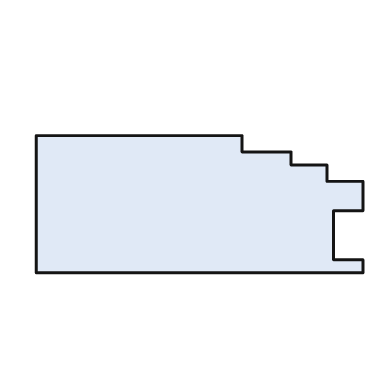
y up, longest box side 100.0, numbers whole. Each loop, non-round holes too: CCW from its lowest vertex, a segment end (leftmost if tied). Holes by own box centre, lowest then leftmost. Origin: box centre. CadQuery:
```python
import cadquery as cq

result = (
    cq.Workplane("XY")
    .moveTo(-50.0, -21.0)
    .lineTo(50.0, -21.0)
    .lineTo(50.0, -17.0)
    .lineTo(41.0, -17.0)
    .lineTo(41.0, -2.0)
    .lineTo(50.0, -2.0)
    .lineTo(50.0, 7.0)
    .lineTo(39.0, 7.0)
    .lineTo(39.0, 12.0)
    .lineTo(28.0, 12.0)
    .lineTo(28.0, 16.0)
    .lineTo(13.0, 16.0)
    .lineTo(13.0, 21.0)
    .lineTo(-50.0, 21.0)
    .close()
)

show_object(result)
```